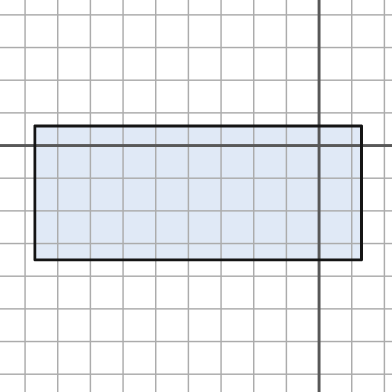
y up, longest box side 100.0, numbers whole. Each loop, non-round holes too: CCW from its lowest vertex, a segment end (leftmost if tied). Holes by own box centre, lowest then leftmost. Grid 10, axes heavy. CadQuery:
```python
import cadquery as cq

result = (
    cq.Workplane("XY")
    .moveTo(-87.0, -35.0)
    .lineTo(13.0, -35.0)
    .lineTo(13.0, 6.0)
    .lineTo(-87.0, 6.0)
    .close()
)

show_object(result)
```